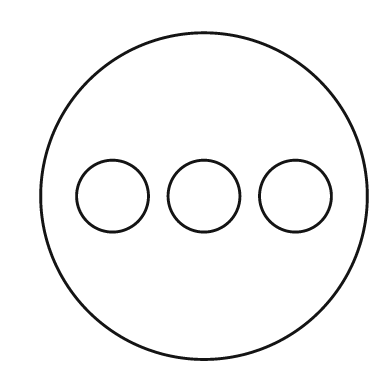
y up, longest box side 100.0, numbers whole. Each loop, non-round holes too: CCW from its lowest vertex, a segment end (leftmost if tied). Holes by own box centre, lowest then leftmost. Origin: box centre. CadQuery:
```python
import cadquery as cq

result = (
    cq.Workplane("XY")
    .moveTo(0.0, 0.0)
    .circle(50.0)
    .moveTo(-28.0, 0.0)
    .circle(11.0)
    .moveTo(0.0, 0.0)
    .circle(11.0)
    .moveTo(28.0, 0.0)
    .circle(11.0)
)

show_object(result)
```